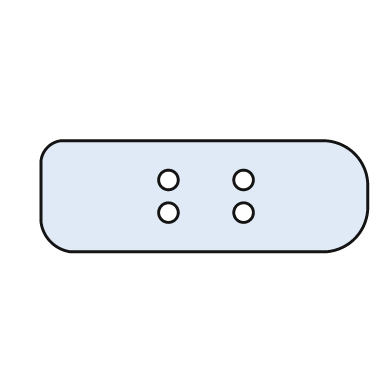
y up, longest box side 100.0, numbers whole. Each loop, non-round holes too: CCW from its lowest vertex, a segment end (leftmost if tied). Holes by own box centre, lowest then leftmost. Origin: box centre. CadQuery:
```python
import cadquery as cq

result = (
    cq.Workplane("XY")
    .moveTo(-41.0, -17.0)
    .lineTo(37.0, -17.0)
    .threePointArc((46.0, -13.0), (50.0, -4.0))
    .lineTo(50.0, 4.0)
    .threePointArc((46.0, 13.0), (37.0, 17.0))
    .lineTo(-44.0, 17.0)
    .threePointArc((-48.0, 15.0), (-50.0, 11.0))
    .lineTo(-50.0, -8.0)
    .threePointArc((-47.0, -14.0), (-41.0, -17.0))
    .close()
    .moveTo(-11.0, -5.0)
    .circle(3.0)
    .moveTo(12.0, -5.0)
    .circle(3.0)
    .moveTo(-11.0, 5.0)
    .circle(3.0)
    .moveTo(12.0, 5.0)
    .circle(3.0)
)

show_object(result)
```